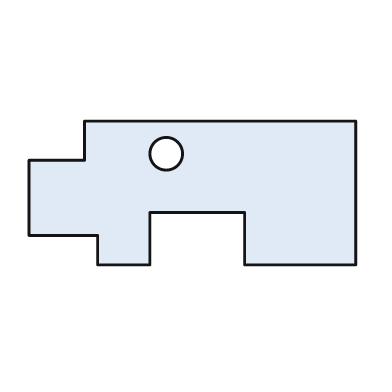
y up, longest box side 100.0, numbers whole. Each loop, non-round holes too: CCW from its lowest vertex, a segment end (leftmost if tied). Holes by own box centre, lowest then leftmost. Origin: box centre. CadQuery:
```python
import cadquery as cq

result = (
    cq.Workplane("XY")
    .moveTo(-29.0, -22.0)
    .lineTo(-13.0, -22.0)
    .lineTo(-13.0, -6.0)
    .lineTo(16.0, -6.0)
    .lineTo(16.0, -22.0)
    .lineTo(50.0, -22.0)
    .lineTo(50.0, 22.0)
    .lineTo(-33.0, 22.0)
    .lineTo(-33.0, 10.0)
    .lineTo(-50.0, 10.0)
    .lineTo(-50.0, -13.0)
    .lineTo(-29.0, -13.0)
    .close()
    .moveTo(-8.0, 12.0)
    .circle(5.0)
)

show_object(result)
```